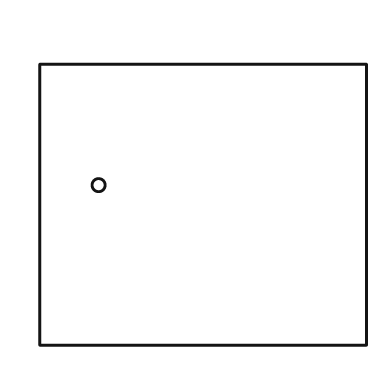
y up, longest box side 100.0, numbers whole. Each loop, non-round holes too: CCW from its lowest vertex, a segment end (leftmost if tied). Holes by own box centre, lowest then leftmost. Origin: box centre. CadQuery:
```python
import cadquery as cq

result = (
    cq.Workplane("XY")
    .moveTo(-50.0, -43.0)
    .lineTo(50.0, -43.0)
    .lineTo(50.0, 43.0)
    .lineTo(-50.0, 43.0)
    .close()
    .moveTo(-32.0, 6.0)
    .circle(2.0)
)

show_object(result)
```